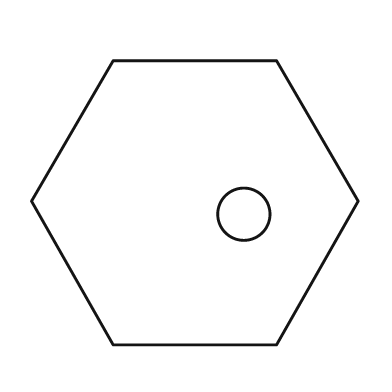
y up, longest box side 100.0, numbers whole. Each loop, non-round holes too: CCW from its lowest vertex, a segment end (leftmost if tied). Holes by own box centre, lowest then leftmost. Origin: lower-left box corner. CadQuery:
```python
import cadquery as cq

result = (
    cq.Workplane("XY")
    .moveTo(25.0, 0.0)
    .lineTo(75.0, 0.0)
    .lineTo(100.0, 44.0)
    .lineTo(75.0, 87.0)
    .lineTo(25.0, 87.0)
    .lineTo(0.0, 44.0)
    .close()
    .moveTo(65.0, 40.0)
    .circle(8.0)
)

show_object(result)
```